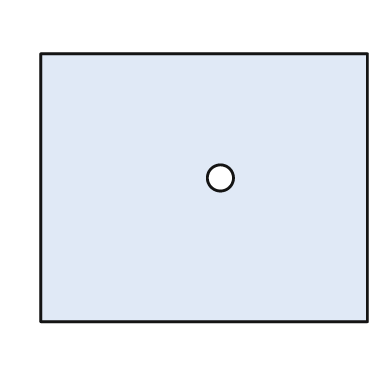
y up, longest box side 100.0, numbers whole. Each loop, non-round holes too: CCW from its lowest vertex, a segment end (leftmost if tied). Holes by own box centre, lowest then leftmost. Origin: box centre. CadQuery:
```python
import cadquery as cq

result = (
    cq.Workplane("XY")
    .moveTo(-50.0, -41.0)
    .lineTo(50.0, -41.0)
    .lineTo(50.0, 41.0)
    .lineTo(-50.0, 41.0)
    .close()
    .moveTo(5.0, 3.0)
    .circle(4.0)
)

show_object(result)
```